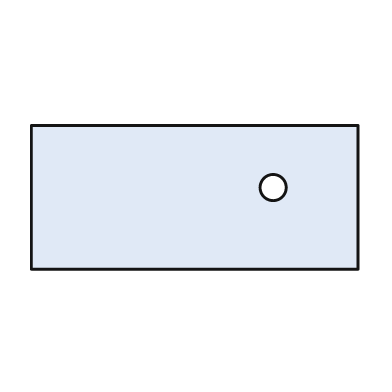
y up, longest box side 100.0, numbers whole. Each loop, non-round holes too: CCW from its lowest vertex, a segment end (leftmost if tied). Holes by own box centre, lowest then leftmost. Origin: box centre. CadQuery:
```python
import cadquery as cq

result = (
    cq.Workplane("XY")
    .moveTo(-50.0, -22.0)
    .lineTo(50.0, -22.0)
    .lineTo(50.0, 22.0)
    .lineTo(-50.0, 22.0)
    .close()
    .moveTo(24.0, 3.0)
    .circle(4.0)
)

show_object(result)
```